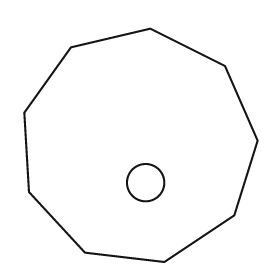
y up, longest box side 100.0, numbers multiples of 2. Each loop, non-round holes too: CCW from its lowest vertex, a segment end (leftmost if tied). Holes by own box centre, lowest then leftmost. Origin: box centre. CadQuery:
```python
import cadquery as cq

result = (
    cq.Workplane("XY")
    .moveTo(10.0, -50.0)
    .lineTo(40.0, -30.0)
    .lineTo(50.0, 2.0)
    .lineTo(36.0, 34.0)
    .lineTo(4.0, 50.0)
    .lineTo(-30.0, 42.0)
    .lineTo(-50.0, 14.0)
    .lineTo(-48.0, -20.0)
    .lineTo(-24.0, -46.0)
    .close()
    .moveTo(2.0, -16.0)
    .circle(8.0)
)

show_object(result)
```